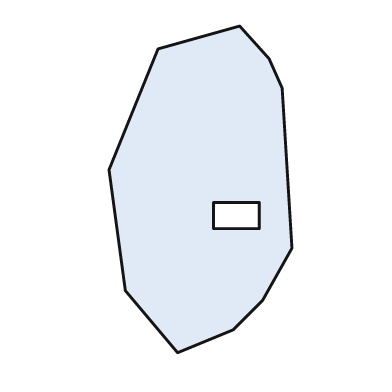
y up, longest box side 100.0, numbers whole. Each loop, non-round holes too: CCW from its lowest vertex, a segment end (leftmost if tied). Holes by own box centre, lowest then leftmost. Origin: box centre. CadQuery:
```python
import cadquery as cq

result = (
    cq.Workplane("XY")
    .moveTo(-7.0, -50.0)
    .lineTo(10.0, -43.0)
    .lineTo(19.0, -34.0)
    .lineTo(28.0, -18.0)
    .lineTo(25.0, 31.0)
    .lineTo(21.0, 40.0)
    .lineTo(12.0, 50.0)
    .lineTo(-13.0, 43.0)
    .lineTo(-28.0, 6.0)
    .lineTo(-23.0, -31.0)
    .close()
    .moveTo(4.0, -12.0)
    .lineTo(18.0, -12.0)
    .lineTo(18.0, -4.0)
    .lineTo(4.0, -4.0)
    .close()
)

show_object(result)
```